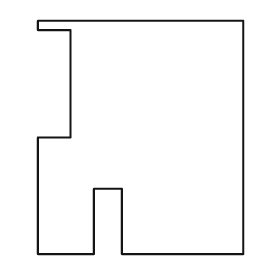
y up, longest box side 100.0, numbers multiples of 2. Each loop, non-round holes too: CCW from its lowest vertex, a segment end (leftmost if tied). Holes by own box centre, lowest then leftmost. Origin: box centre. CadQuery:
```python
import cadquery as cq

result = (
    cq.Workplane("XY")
    .moveTo(-44.0, -50.0)
    .lineTo(-20.0, -50.0)
    .lineTo(-20.0, -22.0)
    .lineTo(-8.0, -22.0)
    .lineTo(-8.0, -50.0)
    .lineTo(44.0, -50.0)
    .lineTo(44.0, 50.0)
    .lineTo(-44.0, 50.0)
    .lineTo(-44.0, 46.0)
    .lineTo(-30.0, 46.0)
    .lineTo(-30.0, 0.0)
    .lineTo(-44.0, 0.0)
    .close()
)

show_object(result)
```